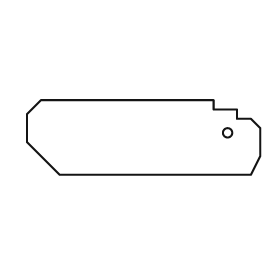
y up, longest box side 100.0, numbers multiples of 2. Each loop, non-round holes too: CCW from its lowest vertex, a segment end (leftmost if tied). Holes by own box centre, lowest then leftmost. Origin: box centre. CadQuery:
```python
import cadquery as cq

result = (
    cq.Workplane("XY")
    .moveTo(-36.0, -16.0)
    .lineTo(46.0, -16.0)
    .lineTo(50.0, -8.0)
    .lineTo(50.0, 4.0)
    .lineTo(46.0, 8.0)
    .lineTo(40.0, 8.0)
    .lineTo(40.0, 12.0)
    .lineTo(30.0, 12.0)
    .lineTo(30.0, 16.0)
    .lineTo(-44.0, 16.0)
    .lineTo(-50.0, 10.0)
    .lineTo(-50.0, -2.0)
    .close()
    .moveTo(36.0, 2.0)
    .circle(2.0)
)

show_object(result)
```